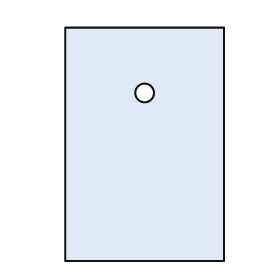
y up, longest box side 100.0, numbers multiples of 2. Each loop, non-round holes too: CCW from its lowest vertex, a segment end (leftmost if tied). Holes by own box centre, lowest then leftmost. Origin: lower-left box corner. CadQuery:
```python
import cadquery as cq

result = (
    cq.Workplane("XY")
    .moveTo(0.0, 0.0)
    .lineTo(68.0, 0.0)
    .lineTo(68.0, 100.0)
    .lineTo(0.0, 100.0)
    .close()
    .moveTo(34.0, 72.0)
    .circle(4.0)
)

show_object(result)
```